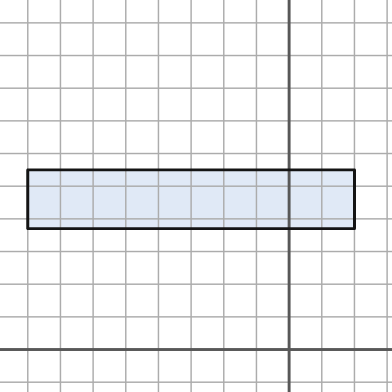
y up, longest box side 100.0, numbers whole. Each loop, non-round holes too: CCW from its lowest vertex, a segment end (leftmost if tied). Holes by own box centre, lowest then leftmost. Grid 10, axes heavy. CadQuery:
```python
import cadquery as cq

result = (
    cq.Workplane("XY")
    .moveTo(-80.0, 37.0)
    .lineTo(20.0, 37.0)
    .lineTo(20.0, 55.0)
    .lineTo(-80.0, 55.0)
    .close()
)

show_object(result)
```